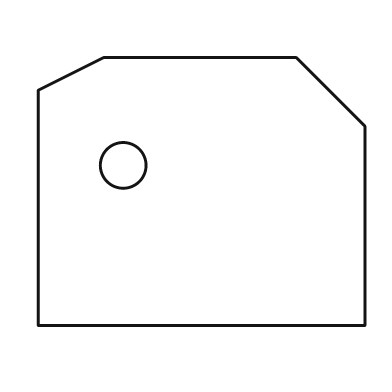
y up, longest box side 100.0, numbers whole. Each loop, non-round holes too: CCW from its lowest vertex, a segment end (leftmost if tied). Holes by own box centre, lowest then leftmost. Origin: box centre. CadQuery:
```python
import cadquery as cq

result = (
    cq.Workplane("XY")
    .moveTo(-50.0, -41.0)
    .lineTo(50.0, -41.0)
    .lineTo(50.0, 20.0)
    .lineTo(29.0, 41.0)
    .lineTo(-30.0, 41.0)
    .lineTo(-50.0, 31.0)
    .close()
    .moveTo(-24.0, 8.0)
    .circle(7.0)
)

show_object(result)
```